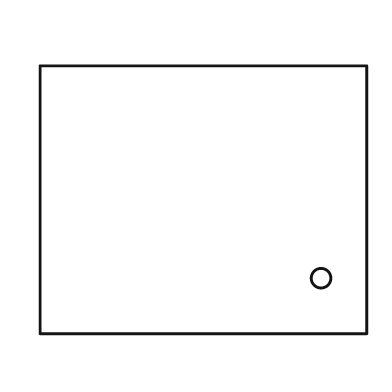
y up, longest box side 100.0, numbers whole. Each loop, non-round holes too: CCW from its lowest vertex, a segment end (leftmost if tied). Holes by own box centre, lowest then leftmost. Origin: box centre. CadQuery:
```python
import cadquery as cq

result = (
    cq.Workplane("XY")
    .moveTo(-50.0, -41.0)
    .lineTo(50.0, -41.0)
    .lineTo(50.0, 41.0)
    .lineTo(-50.0, 41.0)
    .close()
    .moveTo(36.0, -24.0)
    .circle(3.0)
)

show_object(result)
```